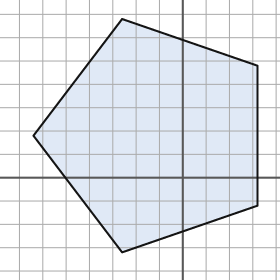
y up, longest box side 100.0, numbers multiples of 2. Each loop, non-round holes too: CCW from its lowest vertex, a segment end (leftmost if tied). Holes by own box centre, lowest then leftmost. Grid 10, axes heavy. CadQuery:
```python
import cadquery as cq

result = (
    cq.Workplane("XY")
    .moveTo(-26.0, -32.0)
    .lineTo(32.0, -12.0)
    .lineTo(32.0, 48.0)
    .lineTo(-26.0, 68.0)
    .lineTo(-64.0, 18.0)
    .close()
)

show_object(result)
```